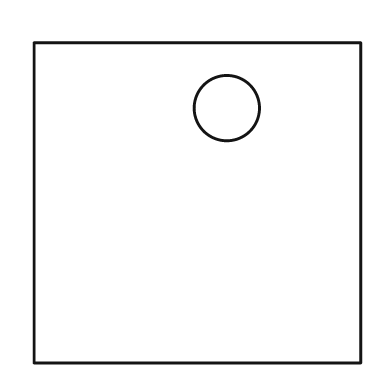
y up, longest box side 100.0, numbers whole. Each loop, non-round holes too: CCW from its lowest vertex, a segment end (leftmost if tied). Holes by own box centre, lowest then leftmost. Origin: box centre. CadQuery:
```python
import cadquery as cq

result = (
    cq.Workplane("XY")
    .moveTo(-50.0, -49.0)
    .lineTo(50.0, -49.0)
    .lineTo(50.0, 49.0)
    .lineTo(-50.0, 49.0)
    .close()
    .moveTo(9.0, 29.0)
    .circle(10.0)
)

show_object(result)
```